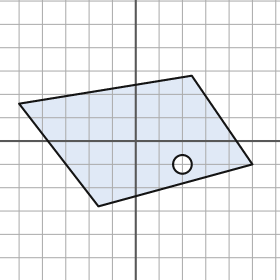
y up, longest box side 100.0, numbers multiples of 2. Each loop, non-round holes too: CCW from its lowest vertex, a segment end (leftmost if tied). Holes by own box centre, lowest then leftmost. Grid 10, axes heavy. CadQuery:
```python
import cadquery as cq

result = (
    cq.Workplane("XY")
    .moveTo(-16.0, -28.0)
    .lineTo(50.0, -10.0)
    .lineTo(24.0, 28.0)
    .lineTo(-50.0, 16.0)
    .close()
    .moveTo(20.0, -10.0)
    .circle(4.0)
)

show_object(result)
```